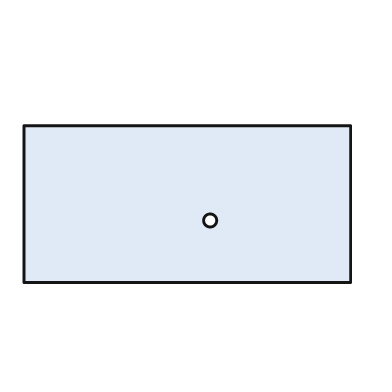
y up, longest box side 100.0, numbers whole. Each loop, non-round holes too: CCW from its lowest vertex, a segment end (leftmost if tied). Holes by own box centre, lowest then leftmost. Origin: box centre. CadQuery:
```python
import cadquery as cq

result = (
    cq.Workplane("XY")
    .moveTo(-50.0, -24.0)
    .lineTo(50.0, -24.0)
    .lineTo(50.0, 24.0)
    .lineTo(-50.0, 24.0)
    .close()
    .moveTo(7.0, -5.0)
    .circle(2.0)
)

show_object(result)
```